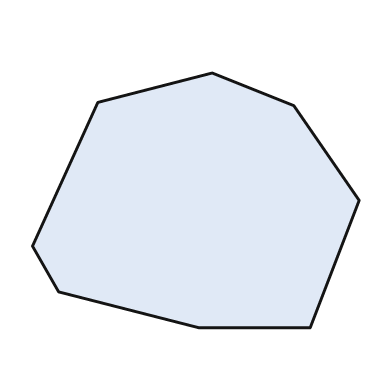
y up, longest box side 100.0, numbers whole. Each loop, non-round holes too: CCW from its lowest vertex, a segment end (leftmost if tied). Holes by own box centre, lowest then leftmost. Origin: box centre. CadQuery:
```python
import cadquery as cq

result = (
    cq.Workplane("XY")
    .moveTo(1.0, -39.0)
    .lineTo(35.0, -39.0)
    .lineTo(50.0, 0.0)
    .lineTo(30.0, 29.0)
    .lineTo(5.0, 39.0)
    .lineTo(-30.0, 30.0)
    .lineTo(-50.0, -14.0)
    .lineTo(-42.0, -28.0)
    .close()
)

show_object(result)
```